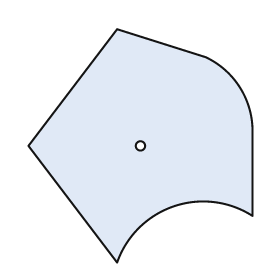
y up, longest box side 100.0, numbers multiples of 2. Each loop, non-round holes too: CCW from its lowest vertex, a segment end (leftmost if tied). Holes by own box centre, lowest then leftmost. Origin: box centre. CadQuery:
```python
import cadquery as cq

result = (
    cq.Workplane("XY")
    .moveTo(-10.0, -50.0)
    .threePointArc((14.0, -26.0), (48.0, -30.0))
    .lineTo(48.0, 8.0)
    .threePointArc((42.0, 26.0), (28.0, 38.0))
    .lineTo(-10.0, 50.0)
    .lineTo(-48.0, 0.0)
    .close()
    .moveTo(0.0, 0.0)
    .circle(2.0)
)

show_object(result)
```